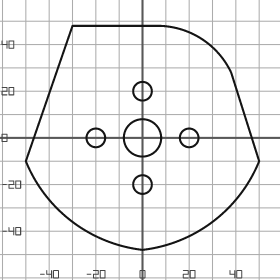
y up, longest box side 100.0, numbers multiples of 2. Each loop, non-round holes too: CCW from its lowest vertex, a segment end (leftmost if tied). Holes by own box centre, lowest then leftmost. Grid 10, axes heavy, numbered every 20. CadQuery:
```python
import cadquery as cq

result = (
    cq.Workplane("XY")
    .moveTo(0.0, -48.0)
    .threePointArc((30.0, -36.0), (50.0, -10.0))
    .lineTo(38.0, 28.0)
    .threePointArc((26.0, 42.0), (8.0, 48.0))
    .lineTo(-30.0, 48.0)
    .lineTo(-50.0, -10.0)
    .threePointArc((-30.0, -36.0), (0.0, -48.0))
    .close()
    .moveTo(0.0, -20.0)
    .circle(4.0)
    .moveTo(-20.0, 0.0)
    .circle(4.0)
    .moveTo(0.0, 0.0)
    .circle(8.0)
    .moveTo(20.0, 0.0)
    .circle(4.0)
    .moveTo(0.0, 20.0)
    .circle(4.0)
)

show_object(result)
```